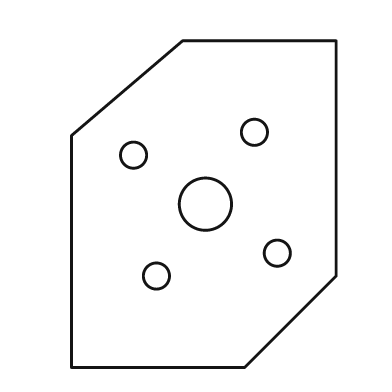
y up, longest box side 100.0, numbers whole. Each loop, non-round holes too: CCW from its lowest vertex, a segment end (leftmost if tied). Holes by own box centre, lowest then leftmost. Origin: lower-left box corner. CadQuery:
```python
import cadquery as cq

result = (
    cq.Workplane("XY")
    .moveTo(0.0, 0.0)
    .lineTo(53.0, 0.0)
    .lineTo(81.0, 28.0)
    .lineTo(81.0, 100.0)
    .lineTo(34.0, 100.0)
    .lineTo(0.0, 71.0)
    .close()
    .moveTo(26.0, 28.0)
    .circle(4.0)
    .moveTo(63.0, 35.0)
    .circle(4.0)
    .moveTo(41.0, 50.0)
    .circle(8.0)
    .moveTo(19.0, 65.0)
    .circle(4.0)
    .moveTo(56.0, 72.0)
    .circle(4.0)
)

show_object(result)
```